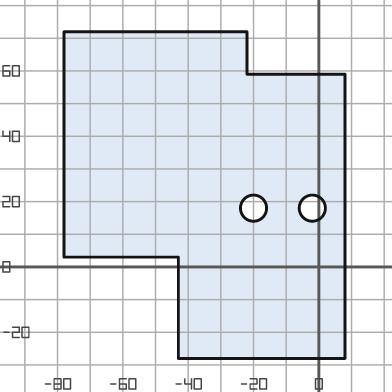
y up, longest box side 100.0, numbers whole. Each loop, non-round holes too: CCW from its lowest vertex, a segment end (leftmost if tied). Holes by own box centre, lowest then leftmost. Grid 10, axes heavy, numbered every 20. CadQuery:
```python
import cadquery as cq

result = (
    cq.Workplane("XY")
    .moveTo(-43.0, -28.0)
    .lineTo(8.0, -28.0)
    .lineTo(8.0, 59.0)
    .lineTo(-22.0, 59.0)
    .lineTo(-22.0, 72.0)
    .lineTo(-78.0, 72.0)
    .lineTo(-78.0, 3.0)
    .lineTo(-43.0, 3.0)
    .close()
    .moveTo(-20.0, 18.0)
    .circle(4.0)
    .moveTo(-2.0, 18.0)
    .circle(4.0)
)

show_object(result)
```